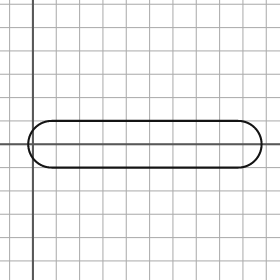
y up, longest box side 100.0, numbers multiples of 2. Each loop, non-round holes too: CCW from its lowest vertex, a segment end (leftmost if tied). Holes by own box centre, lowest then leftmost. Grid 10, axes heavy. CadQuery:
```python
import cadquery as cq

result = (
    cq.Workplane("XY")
    .moveTo(8.0, -10.0)
    .lineTo(88.0, -10.0)
    .threePointArc((98.0, 0.0), (88.0, 10.0))
    .lineTo(8.0, 10.0)
    .threePointArc((-2.0, 0.0), (8.0, -10.0))
    .close()
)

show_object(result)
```